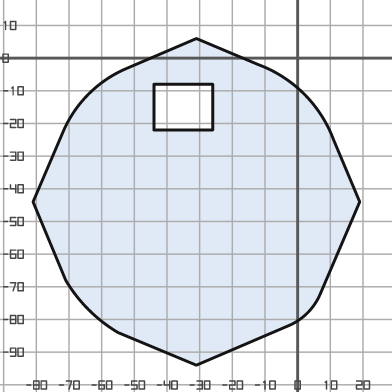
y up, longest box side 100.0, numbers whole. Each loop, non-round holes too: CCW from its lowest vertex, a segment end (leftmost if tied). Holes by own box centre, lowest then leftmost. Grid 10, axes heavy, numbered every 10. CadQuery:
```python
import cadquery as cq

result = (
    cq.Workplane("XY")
    .moveTo(-31.0, -94.0)
    .lineTo(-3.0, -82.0)
    .threePointArc((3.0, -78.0), (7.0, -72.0))
    .lineTo(19.0, -44.0)
    .lineTo(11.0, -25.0)
    .threePointArc((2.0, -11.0), (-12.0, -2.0))
    .lineTo(-31.0, 6.0)
    .lineTo(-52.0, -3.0)
    .threePointArc((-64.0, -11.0), (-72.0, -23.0))
    .lineTo(-81.0, -44.0)
    .lineTo(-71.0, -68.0)
    .threePointArc((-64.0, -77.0), (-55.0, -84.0))
    .close()
    .moveTo(-44.0, -22.0)
    .lineTo(-26.0, -22.0)
    .lineTo(-26.0, -8.0)
    .lineTo(-44.0, -8.0)
    .close()
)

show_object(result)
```